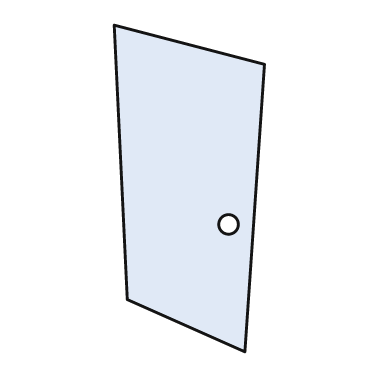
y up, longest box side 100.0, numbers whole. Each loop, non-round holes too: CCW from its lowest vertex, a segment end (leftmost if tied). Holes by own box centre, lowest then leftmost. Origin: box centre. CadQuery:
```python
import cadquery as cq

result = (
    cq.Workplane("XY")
    .moveTo(17.0, -50.0)
    .lineTo(23.0, 38.0)
    .lineTo(-23.0, 50.0)
    .lineTo(-19.0, -34.0)
    .close()
    .moveTo(12.0, -11.0)
    .circle(3.0)
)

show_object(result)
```